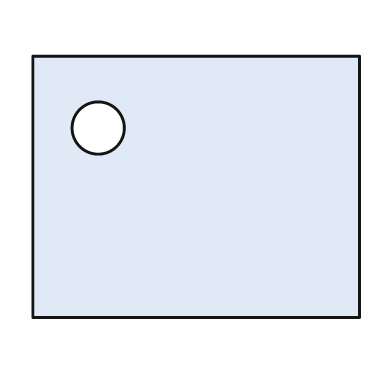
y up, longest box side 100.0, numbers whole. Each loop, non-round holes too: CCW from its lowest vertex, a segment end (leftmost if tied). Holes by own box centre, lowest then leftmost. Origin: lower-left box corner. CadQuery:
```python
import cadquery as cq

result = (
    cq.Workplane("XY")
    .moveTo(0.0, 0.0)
    .lineTo(100.0, 0.0)
    .lineTo(100.0, 80.0)
    .lineTo(0.0, 80.0)
    .close()
    .moveTo(20.0, 58.0)
    .circle(8.0)
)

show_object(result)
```